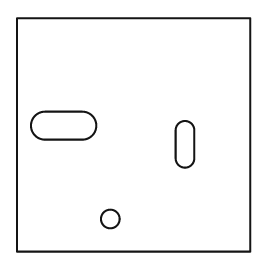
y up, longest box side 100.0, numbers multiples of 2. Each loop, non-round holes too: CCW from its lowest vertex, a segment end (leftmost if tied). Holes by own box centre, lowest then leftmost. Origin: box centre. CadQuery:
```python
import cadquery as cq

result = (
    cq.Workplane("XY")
    .moveTo(-50.0, -50.0)
    .lineTo(50.0, -50.0)
    .lineTo(50.0, 50.0)
    .lineTo(-50.0, 50.0)
    .close()
    .moveTo(-10.0, -36.0)
    .circle(4.0)
    .moveTo(18.0, -10.0)
    .threePointArc((22.0, -14.0), (26.0, -10.0))
    .lineTo(26.0, 2.0)
    .threePointArc((22.0, 6.0), (18.0, 2.0))
    .close()
    .moveTo(-38.0, -2.0)
    .lineTo(-22.0, -2.0)
    .threePointArc((-16.0, 4.0), (-22.0, 10.0))
    .lineTo(-38.0, 10.0)
    .threePointArc((-44.0, 4.0), (-38.0, -2.0))
    .close()
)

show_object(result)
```